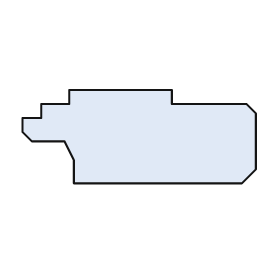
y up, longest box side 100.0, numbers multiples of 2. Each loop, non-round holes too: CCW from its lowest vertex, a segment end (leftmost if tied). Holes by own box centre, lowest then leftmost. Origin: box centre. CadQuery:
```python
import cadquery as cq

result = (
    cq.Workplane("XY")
    .moveTo(-28.0, -20.0)
    .lineTo(44.0, -20.0)
    .lineTo(50.0, -14.0)
    .lineTo(50.0, 10.0)
    .lineTo(46.0, 14.0)
    .lineTo(14.0, 14.0)
    .lineTo(14.0, 20.0)
    .lineTo(-30.0, 20.0)
    .lineTo(-30.0, 14.0)
    .lineTo(-42.0, 14.0)
    .lineTo(-42.0, 8.0)
    .lineTo(-50.0, 8.0)
    .lineTo(-50.0, 2.0)
    .lineTo(-46.0, -2.0)
    .lineTo(-32.0, -2.0)
    .lineTo(-28.0, -10.0)
    .close()
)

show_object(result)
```